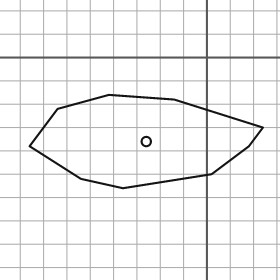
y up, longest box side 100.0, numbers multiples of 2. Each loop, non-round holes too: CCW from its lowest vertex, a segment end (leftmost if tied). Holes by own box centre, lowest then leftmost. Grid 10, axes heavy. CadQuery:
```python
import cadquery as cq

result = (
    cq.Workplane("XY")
    .moveTo(-36.0, -56.0)
    .lineTo(2.0, -50.0)
    .lineTo(18.0, -38.0)
    .lineTo(24.0, -30.0)
    .lineTo(-14.0, -18.0)
    .lineTo(-42.0, -16.0)
    .lineTo(-64.0, -22.0)
    .lineTo(-76.0, -38.0)
    .lineTo(-54.0, -52.0)
    .close()
    .moveTo(-26.0, -36.0)
    .circle(2.0)
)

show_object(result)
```